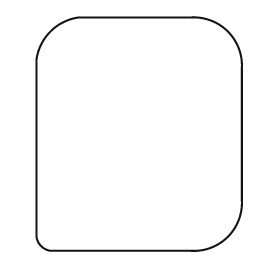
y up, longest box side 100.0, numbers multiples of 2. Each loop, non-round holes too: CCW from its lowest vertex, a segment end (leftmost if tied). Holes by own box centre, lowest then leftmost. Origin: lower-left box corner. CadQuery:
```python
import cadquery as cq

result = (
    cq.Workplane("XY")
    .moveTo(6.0, 0.0)
    .lineTo(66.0, 0.0)
    .threePointArc((82.0, 6.0), (88.0, 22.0))
    .lineTo(88.0, 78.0)
    .threePointArc((82.0, 94.0), (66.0, 100.0))
    .lineTo(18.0, 100.0)
    .threePointArc((6.0, 94.0), (0.0, 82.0))
    .lineTo(0.0, 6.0)
    .threePointArc((2.0, 2.0), (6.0, 0.0))
    .close()
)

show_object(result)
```